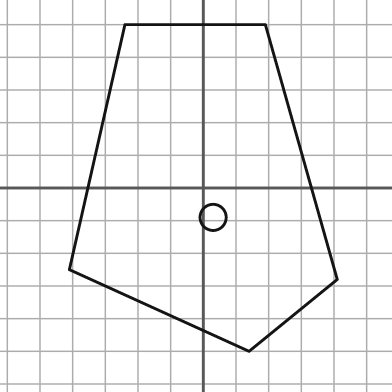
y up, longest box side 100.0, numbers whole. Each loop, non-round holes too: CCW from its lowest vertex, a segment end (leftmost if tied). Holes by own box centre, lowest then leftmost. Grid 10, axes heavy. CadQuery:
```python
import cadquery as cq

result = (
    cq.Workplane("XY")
    .moveTo(14.0, -50.0)
    .lineTo(41.0, -28.0)
    .lineTo(19.0, 50.0)
    .lineTo(-24.0, 50.0)
    .lineTo(-41.0, -25.0)
    .close()
    .moveTo(3.0, -9.0)
    .circle(4.0)
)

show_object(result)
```